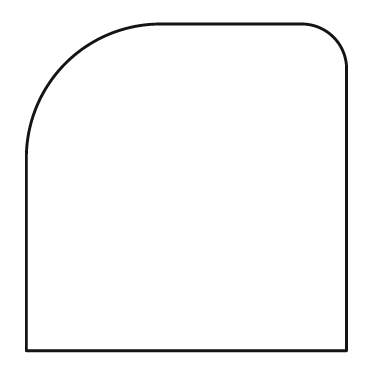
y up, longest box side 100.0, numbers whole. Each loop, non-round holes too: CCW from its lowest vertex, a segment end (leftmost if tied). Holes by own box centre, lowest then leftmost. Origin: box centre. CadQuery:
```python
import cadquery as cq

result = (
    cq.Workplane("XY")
    .moveTo(-49.0, -50.0)
    .lineTo(49.0, -50.0)
    .lineTo(49.0, 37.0)
    .threePointArc((45.0, 46.0), (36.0, 50.0))
    .lineTo(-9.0, 50.0)
    .threePointArc((-37.0, 38.0), (-49.0, 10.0))
    .close()
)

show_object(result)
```